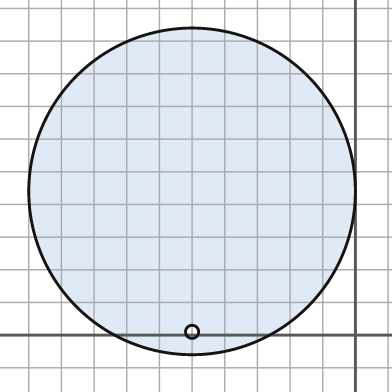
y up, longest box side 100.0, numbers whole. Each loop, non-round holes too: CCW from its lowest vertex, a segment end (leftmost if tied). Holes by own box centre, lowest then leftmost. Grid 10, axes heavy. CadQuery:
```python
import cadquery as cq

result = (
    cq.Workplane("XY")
    .moveTo(-50.0, 44.0)
    .circle(50.0)
    .moveTo(-50.0, 1.0)
    .circle(2.0)
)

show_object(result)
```